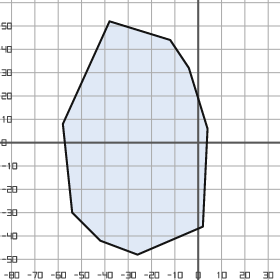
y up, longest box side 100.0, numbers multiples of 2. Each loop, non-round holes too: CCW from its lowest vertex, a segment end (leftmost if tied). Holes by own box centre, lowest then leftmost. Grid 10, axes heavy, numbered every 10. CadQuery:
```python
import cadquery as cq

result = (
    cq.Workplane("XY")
    .moveTo(-26.0, -48.0)
    .lineTo(2.0, -36.0)
    .lineTo(4.0, 6.0)
    .lineTo(-4.0, 32.0)
    .lineTo(-12.0, 44.0)
    .lineTo(-38.0, 52.0)
    .lineTo(-58.0, 8.0)
    .lineTo(-54.0, -30.0)
    .lineTo(-42.0, -42.0)
    .close()
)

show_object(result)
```